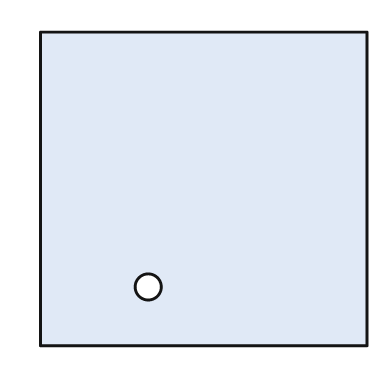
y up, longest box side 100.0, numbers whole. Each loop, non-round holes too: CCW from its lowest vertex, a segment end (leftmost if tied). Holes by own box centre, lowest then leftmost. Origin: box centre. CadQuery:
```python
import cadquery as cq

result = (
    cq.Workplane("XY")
    .moveTo(-50.0, -48.0)
    .lineTo(50.0, -48.0)
    .lineTo(50.0, 48.0)
    .lineTo(-50.0, 48.0)
    .close()
    .moveTo(-17.0, -30.0)
    .circle(4.0)
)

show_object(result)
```